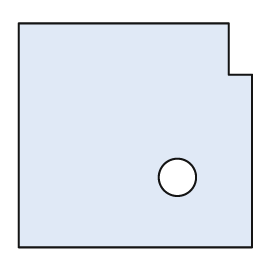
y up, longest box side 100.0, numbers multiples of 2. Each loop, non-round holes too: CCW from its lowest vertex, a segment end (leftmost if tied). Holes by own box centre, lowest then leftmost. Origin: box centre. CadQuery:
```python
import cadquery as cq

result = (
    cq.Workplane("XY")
    .moveTo(-50.0, -48.0)
    .lineTo(50.0, -48.0)
    .lineTo(50.0, 26.0)
    .lineTo(40.0, 26.0)
    .lineTo(40.0, 48.0)
    .lineTo(-50.0, 48.0)
    .close()
    .moveTo(18.0, -18.0)
    .circle(8.0)
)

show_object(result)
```